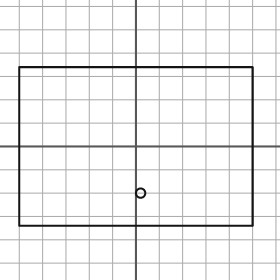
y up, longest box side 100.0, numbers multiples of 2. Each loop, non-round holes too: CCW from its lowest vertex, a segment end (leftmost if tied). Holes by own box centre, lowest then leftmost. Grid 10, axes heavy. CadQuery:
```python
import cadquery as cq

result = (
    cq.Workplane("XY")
    .moveTo(-50.0, -34.0)
    .lineTo(50.0, -34.0)
    .lineTo(50.0, 34.0)
    .lineTo(-50.0, 34.0)
    .close()
    .moveTo(2.0, -20.0)
    .circle(2.0)
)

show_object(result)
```